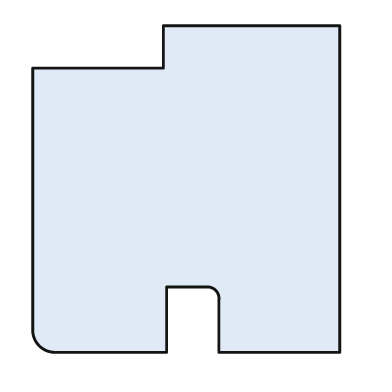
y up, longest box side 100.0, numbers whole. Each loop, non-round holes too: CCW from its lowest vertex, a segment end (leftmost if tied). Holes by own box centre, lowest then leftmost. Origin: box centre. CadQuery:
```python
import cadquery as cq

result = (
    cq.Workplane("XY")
    .moveTo(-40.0, -50.0)
    .lineTo(-6.0, -50.0)
    .lineTo(-6.0, -30.0)
    .lineTo(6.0, -30.0)
    .threePointArc((9.0, -31.0), (10.0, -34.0))
    .lineTo(10.0, -50.0)
    .lineTo(47.0, -50.0)
    .lineTo(47.0, 50.0)
    .lineTo(-7.0, 50.0)
    .lineTo(-7.0, 37.0)
    .lineTo(-47.0, 37.0)
    .lineTo(-47.0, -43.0)
    .threePointArc((-45.0, -48.0), (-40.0, -50.0))
    .close()
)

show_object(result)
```